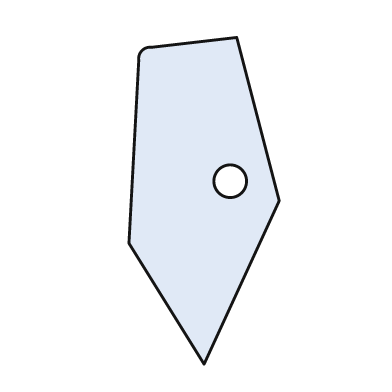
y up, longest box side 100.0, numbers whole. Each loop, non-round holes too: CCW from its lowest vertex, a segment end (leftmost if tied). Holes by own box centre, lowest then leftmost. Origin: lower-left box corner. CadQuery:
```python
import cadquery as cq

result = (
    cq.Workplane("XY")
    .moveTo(23.0, 0.0)
    .lineTo(46.0, 50.0)
    .lineTo(33.0, 100.0)
    .lineTo(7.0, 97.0)
    .threePointArc((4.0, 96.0), (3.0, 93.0))
    .lineTo(0.0, 37.0)
    .close()
    .moveTo(31.0, 56.0)
    .circle(5.0)
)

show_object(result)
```